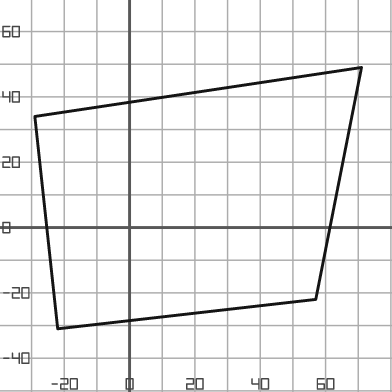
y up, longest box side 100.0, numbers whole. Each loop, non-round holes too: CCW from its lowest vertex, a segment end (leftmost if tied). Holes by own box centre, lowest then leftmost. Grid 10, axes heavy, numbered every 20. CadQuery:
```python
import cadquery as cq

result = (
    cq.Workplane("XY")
    .moveTo(-22.0, -31.0)
    .lineTo(57.0, -22.0)
    .lineTo(71.0, 49.0)
    .lineTo(-29.0, 34.0)
    .close()
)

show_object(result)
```